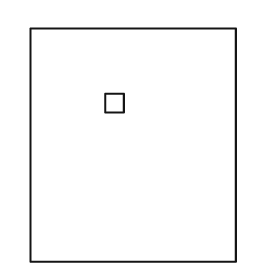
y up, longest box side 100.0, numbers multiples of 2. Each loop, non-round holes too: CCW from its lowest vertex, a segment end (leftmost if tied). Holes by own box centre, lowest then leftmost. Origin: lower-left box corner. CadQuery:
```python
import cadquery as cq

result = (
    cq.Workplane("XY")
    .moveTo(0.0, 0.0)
    .lineTo(88.0, 0.0)
    .lineTo(88.0, 100.0)
    .lineTo(0.0, 100.0)
    .close()
    .moveTo(32.0, 64.0)
    .lineTo(40.0, 64.0)
    .lineTo(40.0, 72.0)
    .lineTo(32.0, 72.0)
    .close()
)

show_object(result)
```